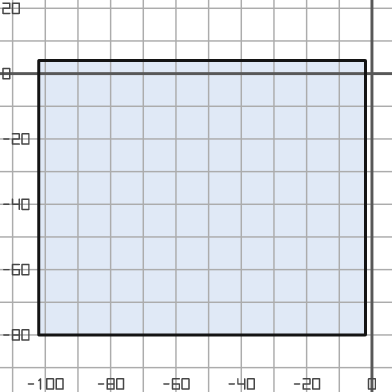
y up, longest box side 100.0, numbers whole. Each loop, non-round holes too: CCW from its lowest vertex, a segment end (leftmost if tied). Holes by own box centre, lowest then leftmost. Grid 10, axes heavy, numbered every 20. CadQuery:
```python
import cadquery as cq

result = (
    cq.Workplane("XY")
    .moveTo(-102.0, -80.0)
    .lineTo(-2.0, -80.0)
    .lineTo(-2.0, 4.0)
    .lineTo(-102.0, 4.0)
    .close()
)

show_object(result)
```